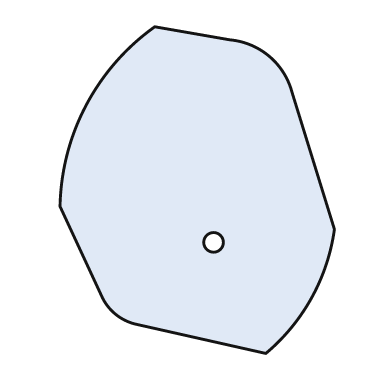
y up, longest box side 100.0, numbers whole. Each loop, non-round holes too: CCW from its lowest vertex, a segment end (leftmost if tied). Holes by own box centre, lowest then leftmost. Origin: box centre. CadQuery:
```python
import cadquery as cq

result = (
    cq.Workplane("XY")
    .moveTo(21.0, -50.0)
    .threePointArc((35.0, -33.0), (42.0, -12.0))
    .lineTo(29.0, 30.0)
    .threePointArc((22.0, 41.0), (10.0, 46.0))
    .lineTo(-13.0, 50.0)
    .threePointArc((-34.0, 26.0), (-42.0, -5.0))
    .lineTo(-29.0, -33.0)
    .threePointArc((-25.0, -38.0), (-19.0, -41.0))
    .close()
    .moveTo(5.0, -16.0)
    .circle(3.0)
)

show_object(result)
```